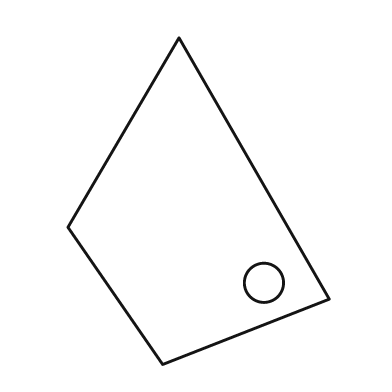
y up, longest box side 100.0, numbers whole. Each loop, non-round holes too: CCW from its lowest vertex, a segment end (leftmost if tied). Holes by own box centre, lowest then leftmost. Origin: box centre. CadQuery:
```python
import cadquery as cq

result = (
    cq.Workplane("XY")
    .moveTo(-11.0, -50.0)
    .lineTo(40.0, -30.0)
    .lineTo(-6.0, 50.0)
    .lineTo(-40.0, -8.0)
    .close()
    .moveTo(20.0, -25.0)
    .circle(6.0)
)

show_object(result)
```